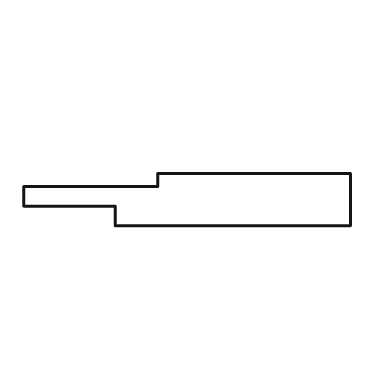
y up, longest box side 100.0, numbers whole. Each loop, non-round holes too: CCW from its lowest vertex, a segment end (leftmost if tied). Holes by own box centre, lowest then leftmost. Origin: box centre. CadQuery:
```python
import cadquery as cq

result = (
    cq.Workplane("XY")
    .moveTo(-22.0, -8.0)
    .lineTo(50.0, -8.0)
    .lineTo(50.0, 8.0)
    .lineTo(-9.0, 8.0)
    .lineTo(-9.0, 4.0)
    .lineTo(-50.0, 4.0)
    .lineTo(-50.0, -2.0)
    .lineTo(-22.0, -2.0)
    .close()
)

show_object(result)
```